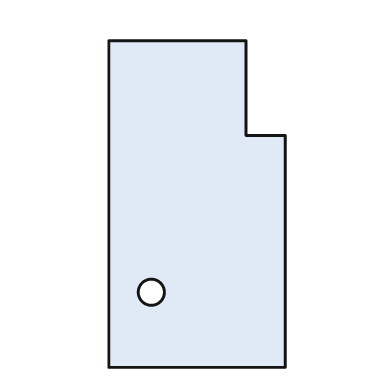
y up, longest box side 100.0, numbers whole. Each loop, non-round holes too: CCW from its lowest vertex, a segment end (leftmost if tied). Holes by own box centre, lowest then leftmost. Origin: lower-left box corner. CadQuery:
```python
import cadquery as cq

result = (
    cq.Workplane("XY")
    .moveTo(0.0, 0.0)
    .lineTo(54.0, 0.0)
    .lineTo(54.0, 71.0)
    .lineTo(42.0, 71.0)
    .lineTo(42.0, 100.0)
    .lineTo(0.0, 100.0)
    .close()
    .moveTo(13.0, 23.0)
    .circle(4.0)
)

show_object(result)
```